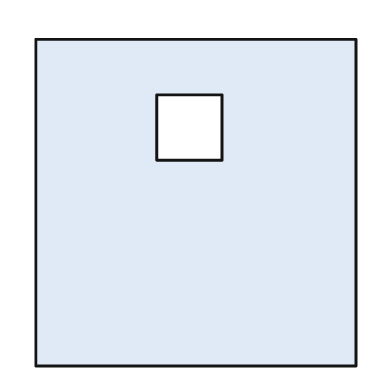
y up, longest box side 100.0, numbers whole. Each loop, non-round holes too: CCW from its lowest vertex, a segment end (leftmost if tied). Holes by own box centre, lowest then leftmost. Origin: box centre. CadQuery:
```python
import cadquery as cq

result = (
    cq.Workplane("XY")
    .moveTo(-49.0, -50.0)
    .lineTo(49.0, -50.0)
    .lineTo(49.0, 50.0)
    .lineTo(-49.0, 50.0)
    .close()
    .moveTo(-12.0, 13.0)
    .lineTo(8.0, 13.0)
    .lineTo(8.0, 33.0)
    .lineTo(-12.0, 33.0)
    .close()
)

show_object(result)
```